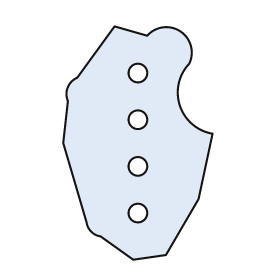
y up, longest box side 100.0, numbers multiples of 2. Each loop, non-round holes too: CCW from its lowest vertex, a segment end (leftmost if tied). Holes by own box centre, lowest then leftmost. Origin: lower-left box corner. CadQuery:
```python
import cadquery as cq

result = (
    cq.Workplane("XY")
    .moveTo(30.0, 0.0)
    .lineTo(44.0, 2.0)
    .lineTo(58.0, 26.0)
    .lineTo(64.0, 54.0)
    .threePointArc((50.0, 66.0), (54.0, 84.0))
    .threePointArc((50.0, 98.0), (36.0, 96.0))
    .lineTo(22.0, 100.0)
    .lineTo(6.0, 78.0)
    .threePointArc((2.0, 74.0), (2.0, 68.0))
    .lineTo(0.0, 50.0)
    .lineTo(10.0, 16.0)
    .threePointArc((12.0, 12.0), (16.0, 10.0))
    .close()
    .moveTo(32.0, 20.0)
    .circle(4.0)
    .moveTo(32.0, 40.0)
    .circle(4.0)
    .moveTo(32.0, 60.0)
    .circle(4.0)
    .moveTo(32.0, 80.0)
    .circle(4.0)
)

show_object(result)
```